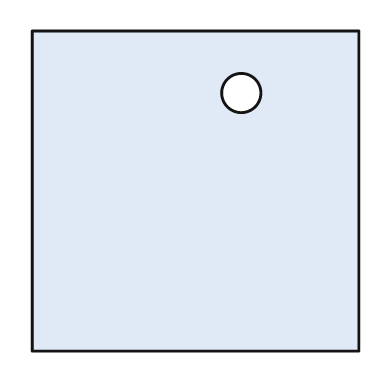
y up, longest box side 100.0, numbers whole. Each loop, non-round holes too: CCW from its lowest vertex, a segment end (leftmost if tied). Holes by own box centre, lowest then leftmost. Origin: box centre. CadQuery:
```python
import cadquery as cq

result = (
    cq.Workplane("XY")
    .moveTo(-50.0, -49.0)
    .lineTo(50.0, -49.0)
    .lineTo(50.0, 49.0)
    .lineTo(-50.0, 49.0)
    .close()
    .moveTo(14.0, 30.0)
    .circle(6.0)
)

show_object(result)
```